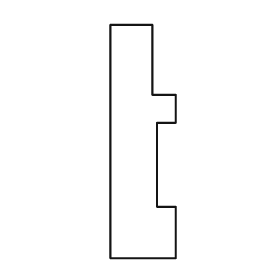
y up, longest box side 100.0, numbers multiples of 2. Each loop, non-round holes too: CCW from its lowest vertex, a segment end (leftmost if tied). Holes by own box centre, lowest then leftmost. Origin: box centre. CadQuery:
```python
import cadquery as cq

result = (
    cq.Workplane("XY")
    .moveTo(-14.0, -50.0)
    .lineTo(14.0, -50.0)
    .lineTo(14.0, -28.0)
    .lineTo(6.0, -28.0)
    .lineTo(6.0, 8.0)
    .lineTo(14.0, 8.0)
    .lineTo(14.0, 20.0)
    .lineTo(4.0, 20.0)
    .lineTo(4.0, 50.0)
    .lineTo(-14.0, 50.0)
    .close()
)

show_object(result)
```